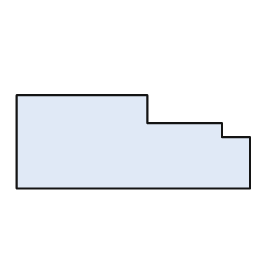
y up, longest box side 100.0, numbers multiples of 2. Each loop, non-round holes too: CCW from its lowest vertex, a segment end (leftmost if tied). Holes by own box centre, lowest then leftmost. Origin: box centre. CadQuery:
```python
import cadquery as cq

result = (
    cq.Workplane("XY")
    .moveTo(-50.0, -20.0)
    .lineTo(50.0, -20.0)
    .lineTo(50.0, 2.0)
    .lineTo(38.0, 2.0)
    .lineTo(38.0, 8.0)
    .lineTo(6.0, 8.0)
    .lineTo(6.0, 20.0)
    .lineTo(-50.0, 20.0)
    .close()
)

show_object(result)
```